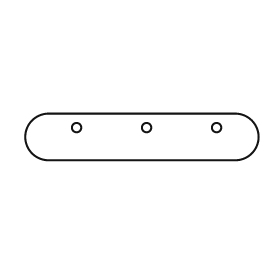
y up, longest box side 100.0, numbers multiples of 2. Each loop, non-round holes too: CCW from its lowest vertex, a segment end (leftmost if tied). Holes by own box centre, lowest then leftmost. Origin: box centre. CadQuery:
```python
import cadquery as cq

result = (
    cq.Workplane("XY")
    .moveTo(-40.0, -10.0)
    .lineTo(40.0, -10.0)
    .threePointArc((50.0, 0.0), (40.0, 10.0))
    .lineTo(-40.0, 10.0)
    .threePointArc((-50.0, 0.0), (-40.0, -10.0))
    .close()
    .moveTo(-28.0, 4.0)
    .circle(2.0)
    .moveTo(2.0, 4.0)
    .circle(2.0)
    .moveTo(32.0, 4.0)
    .circle(2.0)
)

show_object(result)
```